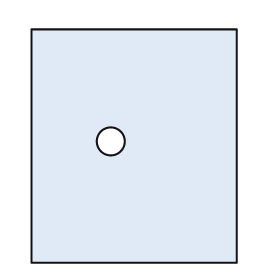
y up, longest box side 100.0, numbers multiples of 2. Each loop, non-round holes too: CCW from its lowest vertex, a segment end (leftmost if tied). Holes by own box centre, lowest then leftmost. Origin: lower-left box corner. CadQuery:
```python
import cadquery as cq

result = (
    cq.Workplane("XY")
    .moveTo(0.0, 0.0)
    .lineTo(88.0, 0.0)
    .lineTo(88.0, 100.0)
    .lineTo(0.0, 100.0)
    .close()
    .moveTo(34.0, 52.0)
    .circle(6.0)
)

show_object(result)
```